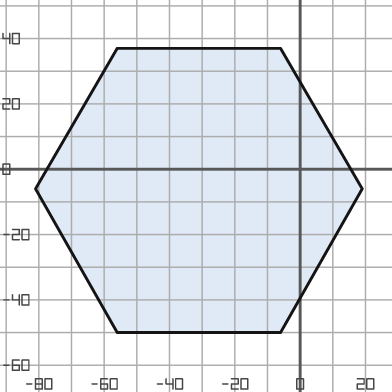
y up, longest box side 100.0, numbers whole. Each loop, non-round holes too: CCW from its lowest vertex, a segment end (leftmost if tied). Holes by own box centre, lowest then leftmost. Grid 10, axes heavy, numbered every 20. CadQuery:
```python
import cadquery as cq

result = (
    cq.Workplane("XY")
    .moveTo(-56.0, -50.0)
    .lineTo(-6.0, -50.0)
    .lineTo(19.0, -6.0)
    .lineTo(-6.0, 37.0)
    .lineTo(-56.0, 37.0)
    .lineTo(-81.0, -6.0)
    .close()
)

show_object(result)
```